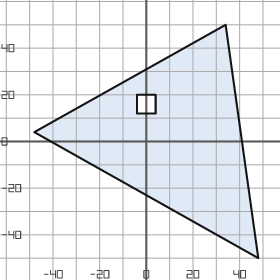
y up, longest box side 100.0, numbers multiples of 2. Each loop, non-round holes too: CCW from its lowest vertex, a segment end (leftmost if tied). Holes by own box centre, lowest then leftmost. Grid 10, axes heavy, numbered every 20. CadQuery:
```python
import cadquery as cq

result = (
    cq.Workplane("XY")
    .moveTo(48.0, -50.0)
    .lineTo(34.0, 50.0)
    .lineTo(-48.0, 4.0)
    .close()
    .moveTo(-4.0, 12.0)
    .lineTo(4.0, 12.0)
    .lineTo(4.0, 20.0)
    .lineTo(-4.0, 20.0)
    .close()
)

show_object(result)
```